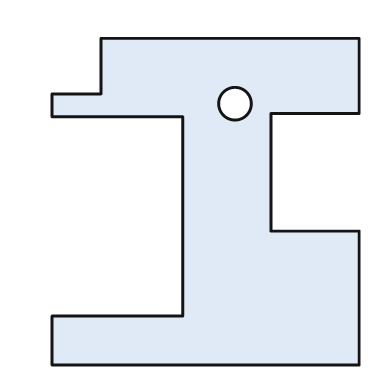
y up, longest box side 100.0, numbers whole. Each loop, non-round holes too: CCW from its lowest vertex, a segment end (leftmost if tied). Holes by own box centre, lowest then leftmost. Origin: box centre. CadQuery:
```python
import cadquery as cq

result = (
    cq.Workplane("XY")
    .moveTo(-47.0, -50.0)
    .lineTo(47.0, -50.0)
    .lineTo(47.0, -9.0)
    .lineTo(20.0, -9.0)
    .lineTo(20.0, 27.0)
    .lineTo(47.0, 27.0)
    .lineTo(47.0, 50.0)
    .lineTo(-32.0, 50.0)
    .lineTo(-32.0, 33.0)
    .lineTo(-47.0, 33.0)
    .lineTo(-47.0, 26.0)
    .lineTo(-7.0, 26.0)
    .lineTo(-7.0, -35.0)
    .lineTo(-47.0, -35.0)
    .close()
    .moveTo(9.0, 30.0)
    .circle(5.0)
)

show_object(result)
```